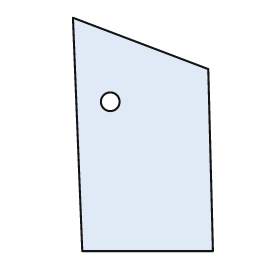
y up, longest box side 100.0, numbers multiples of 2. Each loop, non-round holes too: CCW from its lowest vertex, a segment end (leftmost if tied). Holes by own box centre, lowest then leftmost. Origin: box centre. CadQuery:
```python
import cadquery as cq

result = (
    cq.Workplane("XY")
    .moveTo(-26.0, -50.0)
    .lineTo(30.0, -50.0)
    .lineTo(28.0, 28.0)
    .lineTo(-30.0, 50.0)
    .close()
    .moveTo(-14.0, 14.0)
    .circle(4.0)
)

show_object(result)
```